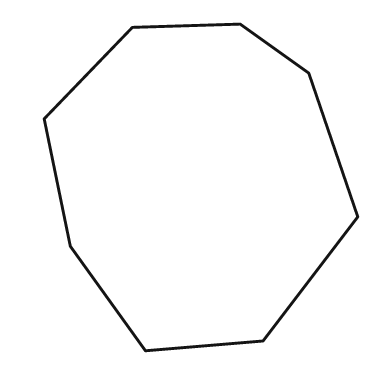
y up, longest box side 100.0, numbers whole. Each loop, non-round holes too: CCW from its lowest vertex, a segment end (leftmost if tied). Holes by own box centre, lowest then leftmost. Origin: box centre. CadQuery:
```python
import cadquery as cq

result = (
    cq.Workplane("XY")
    .moveTo(-17.0, -50.0)
    .lineTo(19.0, -47.0)
    .lineTo(48.0, -9.0)
    .lineTo(33.0, 35.0)
    .lineTo(12.0, 50.0)
    .lineTo(-21.0, 49.0)
    .lineTo(-48.0, 21.0)
    .lineTo(-40.0, -18.0)
    .close()
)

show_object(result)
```